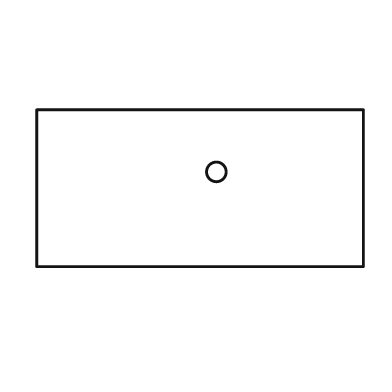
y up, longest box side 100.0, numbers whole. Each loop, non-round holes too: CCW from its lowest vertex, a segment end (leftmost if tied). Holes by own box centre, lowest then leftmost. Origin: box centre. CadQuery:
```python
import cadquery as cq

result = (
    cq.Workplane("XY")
    .moveTo(-50.0, -24.0)
    .lineTo(50.0, -24.0)
    .lineTo(50.0, 24.0)
    .lineTo(-50.0, 24.0)
    .close()
    .moveTo(5.0, 5.0)
    .circle(3.0)
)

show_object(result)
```